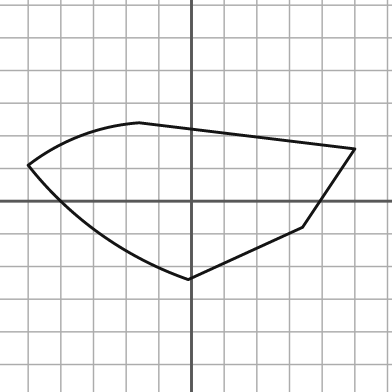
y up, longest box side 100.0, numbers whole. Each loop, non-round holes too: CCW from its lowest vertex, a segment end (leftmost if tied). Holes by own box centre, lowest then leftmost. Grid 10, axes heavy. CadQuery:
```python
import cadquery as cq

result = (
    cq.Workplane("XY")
    .moveTo(-1.0, -24.0)
    .lineTo(34.0, -8.0)
    .lineTo(50.0, 16.0)
    .lineTo(-16.0, 24.0)
    .threePointArc((-34.0, 20.0), (-50.0, 11.0))
    .threePointArc((-28.0, -10.0), (-1.0, -24.0))
    .close()
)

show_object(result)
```